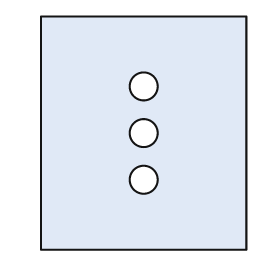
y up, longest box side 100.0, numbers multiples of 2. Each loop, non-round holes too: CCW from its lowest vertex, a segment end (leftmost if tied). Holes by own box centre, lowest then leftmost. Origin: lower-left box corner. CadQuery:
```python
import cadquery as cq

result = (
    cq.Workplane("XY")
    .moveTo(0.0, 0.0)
    .lineTo(88.0, 0.0)
    .lineTo(88.0, 100.0)
    .lineTo(0.0, 100.0)
    .close()
    .moveTo(44.0, 30.0)
    .circle(6.0)
    .moveTo(44.0, 50.0)
    .circle(6.0)
    .moveTo(44.0, 70.0)
    .circle(6.0)
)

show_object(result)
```